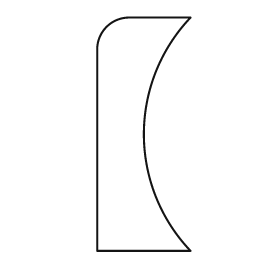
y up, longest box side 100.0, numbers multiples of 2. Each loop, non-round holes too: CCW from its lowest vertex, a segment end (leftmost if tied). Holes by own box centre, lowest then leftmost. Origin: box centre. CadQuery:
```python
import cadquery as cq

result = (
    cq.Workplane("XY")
    .moveTo(-20.0, -50.0)
    .lineTo(20.0, -50.0)
    .threePointArc((0.0, 0.0), (20.0, 50.0))
    .lineTo(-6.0, 50.0)
    .threePointArc((-16.0, 46.0), (-20.0, 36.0))
    .close()
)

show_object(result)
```